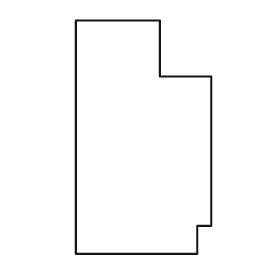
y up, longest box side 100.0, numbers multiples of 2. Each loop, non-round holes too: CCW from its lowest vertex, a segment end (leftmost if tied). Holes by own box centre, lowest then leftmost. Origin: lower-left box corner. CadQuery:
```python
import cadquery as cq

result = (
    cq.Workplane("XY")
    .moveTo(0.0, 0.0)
    .lineTo(52.0, 0.0)
    .lineTo(52.0, 12.0)
    .lineTo(58.0, 12.0)
    .lineTo(58.0, 76.0)
    .lineTo(36.0, 76.0)
    .lineTo(36.0, 100.0)
    .lineTo(0.0, 100.0)
    .close()
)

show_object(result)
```